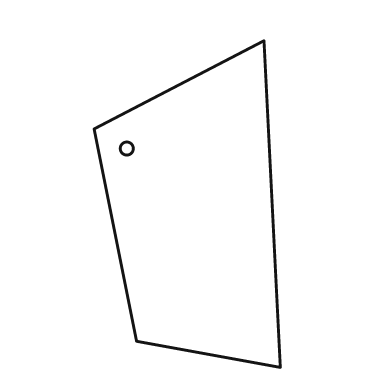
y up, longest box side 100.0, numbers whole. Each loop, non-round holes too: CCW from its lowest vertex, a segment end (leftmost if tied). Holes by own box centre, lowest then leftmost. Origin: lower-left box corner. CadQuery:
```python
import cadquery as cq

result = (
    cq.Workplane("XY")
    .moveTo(57.0, 0.0)
    .lineTo(52.0, 100.0)
    .lineTo(0.0, 73.0)
    .lineTo(13.0, 8.0)
    .close()
    .moveTo(10.0, 67.0)
    .circle(2.0)
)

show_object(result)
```